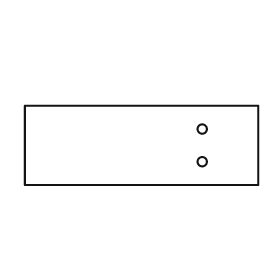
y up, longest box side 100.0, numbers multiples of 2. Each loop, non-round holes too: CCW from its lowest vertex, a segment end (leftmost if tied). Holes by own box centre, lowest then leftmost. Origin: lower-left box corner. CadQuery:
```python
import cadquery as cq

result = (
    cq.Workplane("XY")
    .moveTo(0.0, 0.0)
    .lineTo(100.0, 0.0)
    .lineTo(100.0, 34.0)
    .lineTo(0.0, 34.0)
    .close()
    .moveTo(76.0, 10.0)
    .circle(2.0)
    .moveTo(76.0, 24.0)
    .circle(2.0)
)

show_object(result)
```